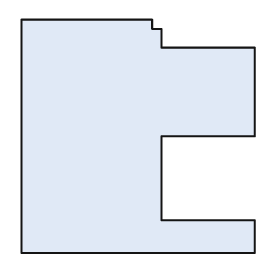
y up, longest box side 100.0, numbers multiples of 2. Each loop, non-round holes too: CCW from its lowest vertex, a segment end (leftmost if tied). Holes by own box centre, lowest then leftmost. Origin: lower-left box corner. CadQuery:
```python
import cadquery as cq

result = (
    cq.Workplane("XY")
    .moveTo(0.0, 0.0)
    .lineTo(100.0, 0.0)
    .lineTo(100.0, 14.0)
    .lineTo(60.0, 14.0)
    .lineTo(60.0, 50.0)
    .lineTo(100.0, 50.0)
    .lineTo(100.0, 88.0)
    .lineTo(60.0, 88.0)
    .lineTo(60.0, 96.0)
    .lineTo(56.0, 96.0)
    .lineTo(56.0, 100.0)
    .lineTo(0.0, 100.0)
    .close()
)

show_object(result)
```